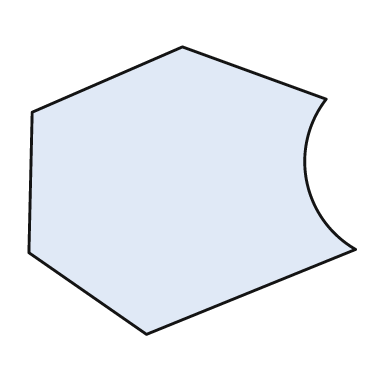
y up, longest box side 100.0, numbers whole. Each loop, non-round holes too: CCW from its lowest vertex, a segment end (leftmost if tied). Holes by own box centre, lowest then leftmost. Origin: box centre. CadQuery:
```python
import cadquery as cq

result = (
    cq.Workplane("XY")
    .moveTo(-14.0, -44.0)
    .lineTo(50.0, -18.0)
    .threePointArc((35.0, 3.0), (41.0, 28.0))
    .lineTo(-3.0, 44.0)
    .lineTo(-49.0, 24.0)
    .lineTo(-50.0, -19.0)
    .close()
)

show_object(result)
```